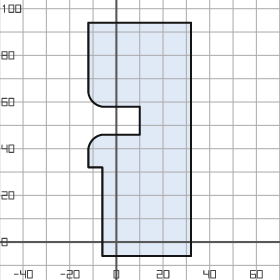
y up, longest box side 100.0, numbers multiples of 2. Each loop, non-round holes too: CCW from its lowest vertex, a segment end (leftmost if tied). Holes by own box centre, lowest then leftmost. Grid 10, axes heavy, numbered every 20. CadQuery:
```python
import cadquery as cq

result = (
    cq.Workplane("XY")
    .moveTo(-6.0, -6.0)
    .lineTo(32.0, -6.0)
    .lineTo(32.0, 94.0)
    .lineTo(-12.0, 94.0)
    .lineTo(-12.0, 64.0)
    .threePointArc((-10.0, 60.0), (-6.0, 58.0))
    .lineTo(10.0, 58.0)
    .lineTo(10.0, 46.0)
    .lineTo(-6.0, 46.0)
    .threePointArc((-10.0, 44.0), (-12.0, 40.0))
    .lineTo(-12.0, 32.0)
    .lineTo(-6.0, 32.0)
    .close()
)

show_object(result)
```